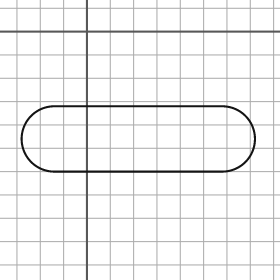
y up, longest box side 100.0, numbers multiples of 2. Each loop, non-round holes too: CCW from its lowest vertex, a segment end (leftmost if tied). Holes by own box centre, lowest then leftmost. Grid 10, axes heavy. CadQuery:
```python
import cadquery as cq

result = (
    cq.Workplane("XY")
    .moveTo(-14.0, -60.0)
    .lineTo(58.0, -60.0)
    .threePointArc((72.0, -46.0), (58.0, -32.0))
    .lineTo(-14.0, -32.0)
    .threePointArc((-28.0, -46.0), (-14.0, -60.0))
    .close()
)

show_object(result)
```